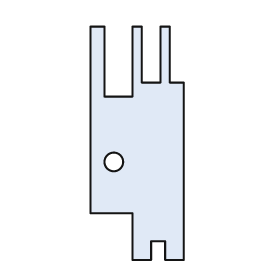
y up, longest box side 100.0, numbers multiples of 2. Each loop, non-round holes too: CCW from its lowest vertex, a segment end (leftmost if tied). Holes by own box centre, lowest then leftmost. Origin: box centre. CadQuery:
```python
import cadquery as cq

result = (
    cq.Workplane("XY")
    .moveTo(-2.0, -50.0)
    .lineTo(6.0, -50.0)
    .lineTo(6.0, -42.0)
    .lineTo(12.0, -42.0)
    .lineTo(12.0, -50.0)
    .lineTo(20.0, -50.0)
    .lineTo(20.0, 26.0)
    .lineTo(14.0, 26.0)
    .lineTo(14.0, 50.0)
    .lineTo(10.0, 50.0)
    .lineTo(10.0, 26.0)
    .lineTo(2.0, 26.0)
    .lineTo(2.0, 50.0)
    .lineTo(-2.0, 50.0)
    .lineTo(-2.0, 20.0)
    .lineTo(-14.0, 20.0)
    .lineTo(-14.0, 50.0)
    .lineTo(-20.0, 50.0)
    .lineTo(-20.0, -30.0)
    .lineTo(-2.0, -30.0)
    .close()
    .moveTo(-10.0, -8.0)
    .circle(4.0)
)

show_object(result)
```